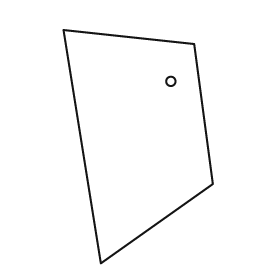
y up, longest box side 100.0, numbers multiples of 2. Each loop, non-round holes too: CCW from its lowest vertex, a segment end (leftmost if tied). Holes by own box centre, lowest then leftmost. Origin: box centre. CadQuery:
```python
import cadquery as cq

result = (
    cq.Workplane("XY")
    .moveTo(-16.0, -50.0)
    .lineTo(32.0, -16.0)
    .lineTo(24.0, 44.0)
    .lineTo(-32.0, 50.0)
    .close()
    .moveTo(14.0, 28.0)
    .circle(2.0)
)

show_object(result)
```